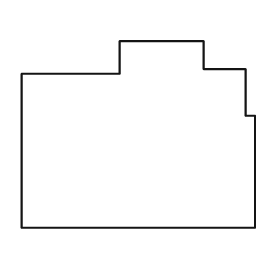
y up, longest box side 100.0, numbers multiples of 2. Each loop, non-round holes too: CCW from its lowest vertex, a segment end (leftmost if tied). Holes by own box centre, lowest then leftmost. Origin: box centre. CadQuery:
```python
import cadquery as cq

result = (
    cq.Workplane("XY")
    .moveTo(-50.0, -40.0)
    .lineTo(50.0, -40.0)
    .lineTo(50.0, 8.0)
    .lineTo(46.0, 8.0)
    .lineTo(46.0, 28.0)
    .lineTo(28.0, 28.0)
    .lineTo(28.0, 40.0)
    .lineTo(-8.0, 40.0)
    .lineTo(-8.0, 26.0)
    .lineTo(-50.0, 26.0)
    .close()
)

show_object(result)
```